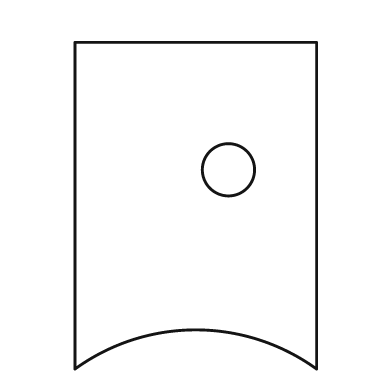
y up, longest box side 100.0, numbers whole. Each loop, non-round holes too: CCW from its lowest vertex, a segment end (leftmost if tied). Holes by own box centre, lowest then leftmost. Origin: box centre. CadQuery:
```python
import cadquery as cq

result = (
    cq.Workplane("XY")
    .moveTo(-37.0, -50.0)
    .threePointArc((0.0, -38.0), (37.0, -50.0))
    .lineTo(37.0, 50.0)
    .lineTo(-37.0, 50.0)
    .close()
    .moveTo(10.0, 11.0)
    .circle(8.0)
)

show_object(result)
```